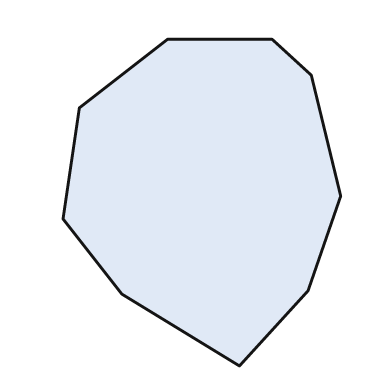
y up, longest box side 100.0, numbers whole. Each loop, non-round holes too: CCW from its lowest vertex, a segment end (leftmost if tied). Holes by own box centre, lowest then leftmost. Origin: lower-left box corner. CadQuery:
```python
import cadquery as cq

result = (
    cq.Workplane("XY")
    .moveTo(54.0, 0.0)
    .lineTo(75.0, 23.0)
    .lineTo(85.0, 52.0)
    .lineTo(76.0, 89.0)
    .lineTo(64.0, 100.0)
    .lineTo(32.0, 100.0)
    .lineTo(5.0, 79.0)
    .lineTo(0.0, 45.0)
    .lineTo(18.0, 22.0)
    .close()
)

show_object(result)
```